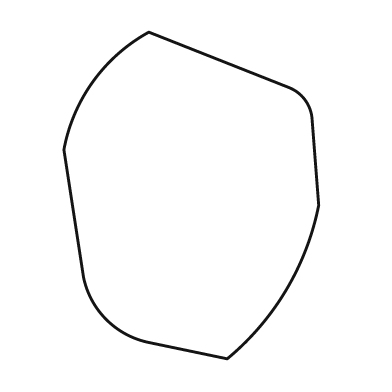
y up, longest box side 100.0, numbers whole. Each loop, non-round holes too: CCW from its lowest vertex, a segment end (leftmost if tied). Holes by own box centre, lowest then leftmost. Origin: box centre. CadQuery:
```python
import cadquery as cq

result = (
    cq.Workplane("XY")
    .moveTo(11.0, -50.0)
    .threePointArc((29.0, -29.0), (39.0, -3.0))
    .lineTo(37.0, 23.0)
    .threePointArc((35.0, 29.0), (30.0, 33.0))
    .lineTo(-13.0, 50.0)
    .threePointArc((-30.0, 35.0), (-39.0, 14.0))
    .lineTo(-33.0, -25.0)
    .threePointArc((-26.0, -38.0), (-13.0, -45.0))
    .close()
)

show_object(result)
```